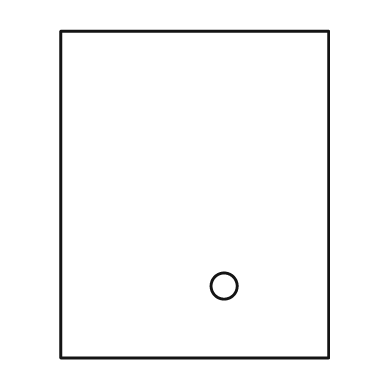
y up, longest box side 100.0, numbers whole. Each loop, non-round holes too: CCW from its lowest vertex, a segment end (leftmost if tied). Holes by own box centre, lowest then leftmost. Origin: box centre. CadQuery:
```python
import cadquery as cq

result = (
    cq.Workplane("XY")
    .moveTo(-41.0, -50.0)
    .lineTo(41.0, -50.0)
    .lineTo(41.0, 50.0)
    .lineTo(-41.0, 50.0)
    .close()
    .moveTo(9.0, -28.0)
    .circle(4.0)
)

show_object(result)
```